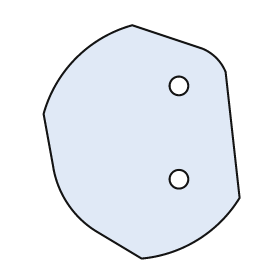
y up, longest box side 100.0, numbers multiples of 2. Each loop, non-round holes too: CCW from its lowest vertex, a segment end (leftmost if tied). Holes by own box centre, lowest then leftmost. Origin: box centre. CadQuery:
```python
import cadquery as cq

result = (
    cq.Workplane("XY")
    .moveTo(0.0, -50.0)
    .threePointArc((24.0, -42.0), (42.0, -24.0))
    .lineTo(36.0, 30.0)
    .threePointArc((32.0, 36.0), (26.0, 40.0))
    .lineTo(-4.0, 50.0)
    .threePointArc((-28.0, 36.0), (-42.0, 12.0))
    .lineTo(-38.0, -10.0)
    .threePointArc((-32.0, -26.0), (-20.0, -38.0))
    .close()
    .moveTo(16.0, -16.0)
    .circle(4.0)
    .moveTo(16.0, 24.0)
    .circle(4.0)
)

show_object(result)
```